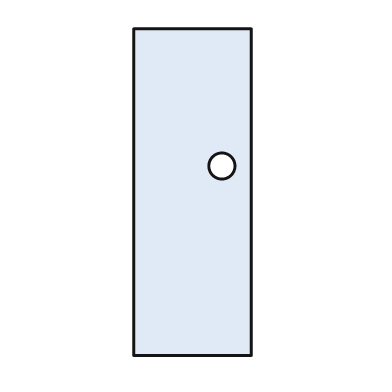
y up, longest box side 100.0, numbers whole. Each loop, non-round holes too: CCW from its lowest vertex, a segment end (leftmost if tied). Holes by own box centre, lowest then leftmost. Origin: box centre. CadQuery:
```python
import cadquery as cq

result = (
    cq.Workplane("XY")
    .moveTo(-18.0, -50.0)
    .lineTo(18.0, -50.0)
    .lineTo(18.0, 50.0)
    .lineTo(-18.0, 50.0)
    .close()
    .moveTo(9.0, 8.0)
    .circle(4.0)
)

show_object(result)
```